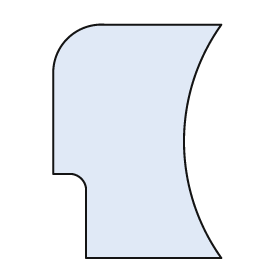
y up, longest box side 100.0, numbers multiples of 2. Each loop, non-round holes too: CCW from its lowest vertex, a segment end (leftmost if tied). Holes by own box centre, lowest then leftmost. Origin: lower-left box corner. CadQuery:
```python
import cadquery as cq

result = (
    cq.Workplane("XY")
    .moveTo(14.0, 0.0)
    .lineTo(72.0, 0.0)
    .threePointArc((56.0, 50.0), (72.0, 100.0))
    .lineTo(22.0, 100.0)
    .threePointArc((6.0, 94.0), (0.0, 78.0))
    .lineTo(0.0, 36.0)
    .lineTo(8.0, 36.0)
    .threePointArc((12.0, 34.0), (14.0, 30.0))
    .close()
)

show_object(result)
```